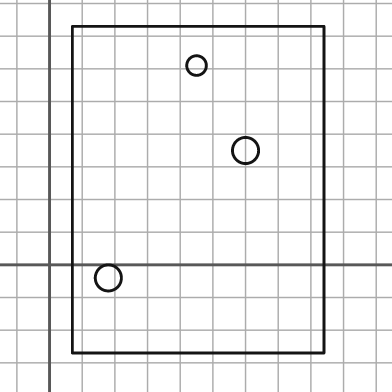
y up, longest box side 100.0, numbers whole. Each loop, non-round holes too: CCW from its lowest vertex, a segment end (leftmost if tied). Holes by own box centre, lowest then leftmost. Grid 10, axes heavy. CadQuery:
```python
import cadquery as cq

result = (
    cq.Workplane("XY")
    .moveTo(7.0, -27.0)
    .lineTo(84.0, -27.0)
    .lineTo(84.0, 73.0)
    .lineTo(7.0, 73.0)
    .close()
    .moveTo(18.0, -4.0)
    .circle(4.0)
    .moveTo(60.0, 35.0)
    .circle(4.0)
    .moveTo(45.0, 61.0)
    .circle(3.0)
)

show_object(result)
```